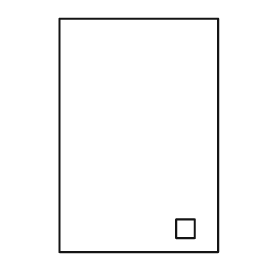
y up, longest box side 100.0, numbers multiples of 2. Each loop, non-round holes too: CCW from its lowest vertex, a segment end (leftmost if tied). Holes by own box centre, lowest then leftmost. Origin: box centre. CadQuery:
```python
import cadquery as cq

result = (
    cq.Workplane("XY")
    .moveTo(-34.0, -50.0)
    .lineTo(34.0, -50.0)
    .lineTo(34.0, 50.0)
    .lineTo(-34.0, 50.0)
    .close()
    .moveTo(16.0, -44.0)
    .lineTo(24.0, -44.0)
    .lineTo(24.0, -36.0)
    .lineTo(16.0, -36.0)
    .close()
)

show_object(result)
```